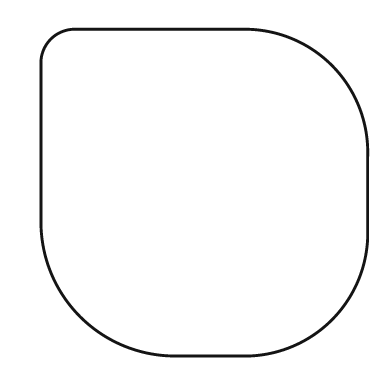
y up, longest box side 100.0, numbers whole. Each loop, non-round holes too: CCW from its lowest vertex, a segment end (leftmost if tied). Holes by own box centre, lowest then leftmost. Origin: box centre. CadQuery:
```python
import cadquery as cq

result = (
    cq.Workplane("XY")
    .moveTo(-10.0, -50.0)
    .lineTo(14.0, -50.0)
    .threePointArc((39.0, -39.0), (50.0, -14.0))
    .lineTo(50.0, 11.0)
    .threePointArc((39.0, 39.0), (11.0, 50.0))
    .lineTo(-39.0, 50.0)
    .threePointArc((-47.0, 47.0), (-50.0, 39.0))
    .lineTo(-50.0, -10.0)
    .threePointArc((-38.0, -38.0), (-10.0, -50.0))
    .close()
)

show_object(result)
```